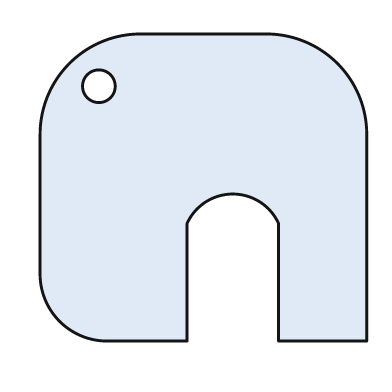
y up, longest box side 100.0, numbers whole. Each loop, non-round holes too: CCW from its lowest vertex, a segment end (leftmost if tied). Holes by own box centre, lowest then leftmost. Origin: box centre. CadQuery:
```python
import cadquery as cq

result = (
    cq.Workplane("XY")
    .moveTo(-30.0, -47.0)
    .lineTo(-5.0, -47.0)
    .lineTo(-5.0, -11.0)
    .threePointArc((9.0, -2.0), (23.0, -11.0))
    .lineTo(23.0, -47.0)
    .lineTo(50.0, -47.0)
    .lineTo(50.0, 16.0)
    .threePointArc((41.0, 38.0), (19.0, 47.0))
    .lineTo(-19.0, 47.0)
    .threePointArc((-41.0, 38.0), (-50.0, 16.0))
    .lineTo(-50.0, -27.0)
    .threePointArc((-44.0, -41.0), (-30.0, -47.0))
    .close()
    .moveTo(-32.0, 31.0)
    .circle(5.0)
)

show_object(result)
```